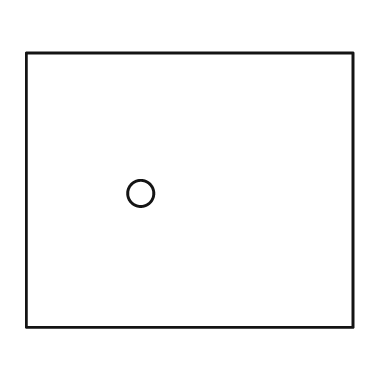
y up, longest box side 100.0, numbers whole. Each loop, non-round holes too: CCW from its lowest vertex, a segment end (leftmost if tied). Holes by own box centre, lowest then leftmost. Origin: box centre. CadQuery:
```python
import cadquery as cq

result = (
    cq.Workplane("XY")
    .moveTo(-50.0, -42.0)
    .lineTo(50.0, -42.0)
    .lineTo(50.0, 42.0)
    .lineTo(-50.0, 42.0)
    .close()
    .moveTo(-15.0, -1.0)
    .circle(4.0)
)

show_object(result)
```